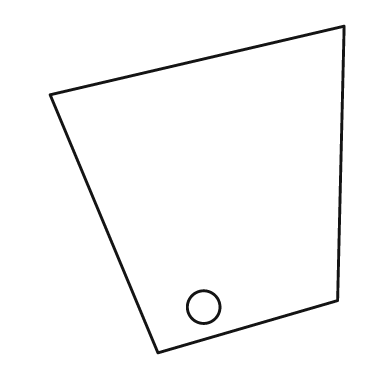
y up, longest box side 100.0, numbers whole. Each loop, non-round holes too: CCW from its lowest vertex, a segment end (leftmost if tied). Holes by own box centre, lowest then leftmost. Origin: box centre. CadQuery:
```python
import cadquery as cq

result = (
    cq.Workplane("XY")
    .moveTo(-12.0, -50.0)
    .lineTo(43.0, -34.0)
    .lineTo(45.0, 50.0)
    .lineTo(-45.0, 29.0)
    .close()
    .moveTo(2.0, -36.0)
    .circle(5.0)
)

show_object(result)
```